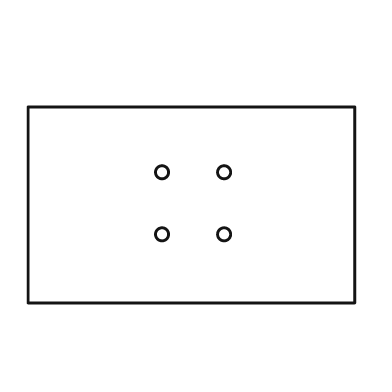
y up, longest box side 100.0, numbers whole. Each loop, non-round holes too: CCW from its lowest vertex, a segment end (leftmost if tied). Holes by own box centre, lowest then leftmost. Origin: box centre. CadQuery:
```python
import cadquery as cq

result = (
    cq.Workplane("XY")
    .moveTo(-50.0, -30.0)
    .lineTo(50.0, -30.0)
    .lineTo(50.0, 30.0)
    .lineTo(-50.0, 30.0)
    .close()
    .moveTo(-9.0, -9.0)
    .circle(2.0)
    .moveTo(10.0, -9.0)
    .circle(2.0)
    .moveTo(-9.0, 10.0)
    .circle(2.0)
    .moveTo(10.0, 10.0)
    .circle(2.0)
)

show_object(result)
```